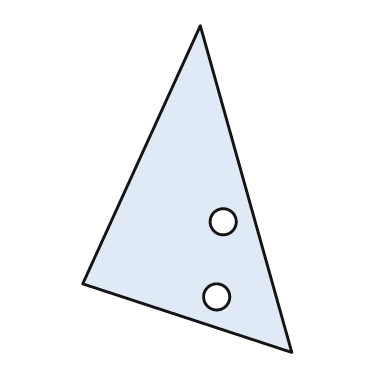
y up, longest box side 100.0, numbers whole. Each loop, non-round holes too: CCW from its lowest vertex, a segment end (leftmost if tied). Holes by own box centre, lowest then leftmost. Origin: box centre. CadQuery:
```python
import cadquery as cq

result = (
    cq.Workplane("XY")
    .moveTo(32.0, -50.0)
    .lineTo(4.0, 50.0)
    .lineTo(-32.0, -29.0)
    .close()
    .moveTo(9.0, -33.0)
    .circle(4.0)
    .moveTo(11.0, -10.0)
    .circle(4.0)
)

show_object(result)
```